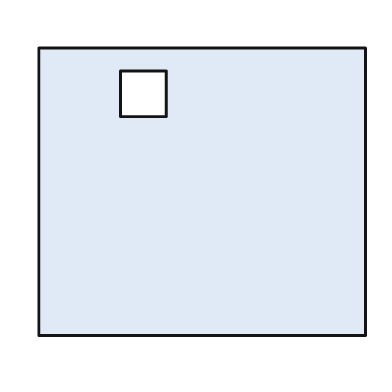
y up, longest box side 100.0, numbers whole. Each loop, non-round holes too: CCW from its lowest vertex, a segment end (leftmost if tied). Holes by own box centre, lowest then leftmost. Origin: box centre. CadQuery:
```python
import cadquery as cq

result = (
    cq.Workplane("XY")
    .moveTo(-50.0, -44.0)
    .lineTo(50.0, -44.0)
    .lineTo(50.0, 44.0)
    .lineTo(-50.0, 44.0)
    .close()
    .moveTo(-25.0, 23.0)
    .lineTo(-11.0, 23.0)
    .lineTo(-11.0, 37.0)
    .lineTo(-25.0, 37.0)
    .close()
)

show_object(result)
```